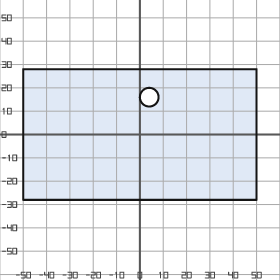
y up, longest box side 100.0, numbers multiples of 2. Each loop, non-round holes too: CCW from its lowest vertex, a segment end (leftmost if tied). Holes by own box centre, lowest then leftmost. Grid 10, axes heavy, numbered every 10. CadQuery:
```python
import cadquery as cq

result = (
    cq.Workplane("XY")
    .moveTo(-50.0, -28.0)
    .lineTo(50.0, -28.0)
    .lineTo(50.0, 28.0)
    .lineTo(-50.0, 28.0)
    .close()
    .moveTo(4.0, 16.0)
    .circle(4.0)
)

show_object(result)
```